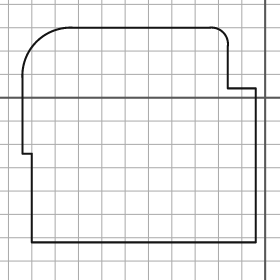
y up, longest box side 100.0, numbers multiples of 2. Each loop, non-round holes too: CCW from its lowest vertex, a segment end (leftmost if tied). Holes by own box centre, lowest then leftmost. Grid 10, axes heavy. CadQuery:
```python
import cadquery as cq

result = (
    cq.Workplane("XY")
    .moveTo(-100.0, -62.0)
    .lineTo(-4.0, -62.0)
    .lineTo(-4.0, 4.0)
    .lineTo(-16.0, 4.0)
    .lineTo(-16.0, 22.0)
    .threePointArc((-18.0, 28.0), (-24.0, 30.0))
    .lineTo(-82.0, 30.0)
    .threePointArc((-98.0, 24.0), (-104.0, 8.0))
    .lineTo(-104.0, -24.0)
    .lineTo(-100.0, -24.0)
    .close()
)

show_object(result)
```